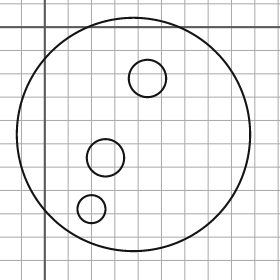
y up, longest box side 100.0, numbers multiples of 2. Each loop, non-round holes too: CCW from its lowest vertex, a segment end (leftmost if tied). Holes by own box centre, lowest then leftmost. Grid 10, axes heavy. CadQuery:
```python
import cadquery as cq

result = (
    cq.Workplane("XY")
    .moveTo(38.0, -46.0)
    .circle(50.0)
    .moveTo(20.0, -78.0)
    .circle(6.0)
    .moveTo(26.0, -56.0)
    .circle(8.0)
    .moveTo(44.0, -22.0)
    .circle(8.0)
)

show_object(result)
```